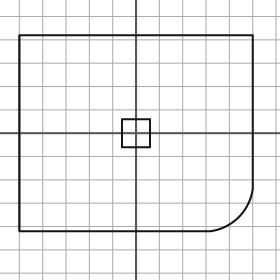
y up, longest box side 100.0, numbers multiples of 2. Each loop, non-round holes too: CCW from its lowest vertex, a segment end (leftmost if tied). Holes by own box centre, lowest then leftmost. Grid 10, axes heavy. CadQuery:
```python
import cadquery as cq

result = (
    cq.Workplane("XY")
    .moveTo(-50.0, -42.0)
    .lineTo(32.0, -42.0)
    .threePointArc((44.0, -36.0), (50.0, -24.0))
    .lineTo(50.0, 42.0)
    .lineTo(-50.0, 42.0)
    .close()
    .moveTo(-6.0, -6.0)
    .lineTo(6.0, -6.0)
    .lineTo(6.0, 6.0)
    .lineTo(-6.0, 6.0)
    .close()
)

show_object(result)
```